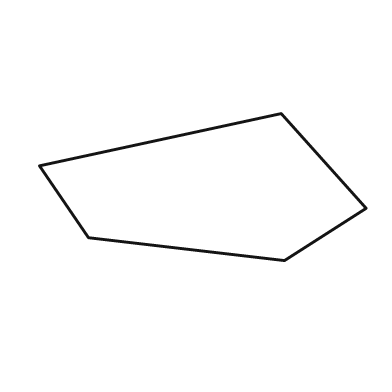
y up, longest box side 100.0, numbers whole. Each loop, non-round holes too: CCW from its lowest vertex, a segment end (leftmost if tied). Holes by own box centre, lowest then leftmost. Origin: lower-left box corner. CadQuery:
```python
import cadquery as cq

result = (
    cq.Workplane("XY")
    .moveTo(75.0, 0.0)
    .lineTo(100.0, 16.0)
    .lineTo(74.0, 45.0)
    .lineTo(0.0, 29.0)
    .lineTo(15.0, 7.0)
    .close()
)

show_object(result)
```